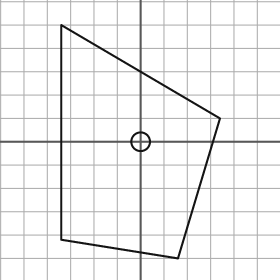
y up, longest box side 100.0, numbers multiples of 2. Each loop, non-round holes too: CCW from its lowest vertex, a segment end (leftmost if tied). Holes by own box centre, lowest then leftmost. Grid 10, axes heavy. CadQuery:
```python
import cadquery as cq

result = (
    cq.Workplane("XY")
    .moveTo(16.0, -50.0)
    .lineTo(34.0, 10.0)
    .lineTo(-34.0, 50.0)
    .lineTo(-34.0, -42.0)
    .close()
    .moveTo(0.0, 0.0)
    .circle(4.0)
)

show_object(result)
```